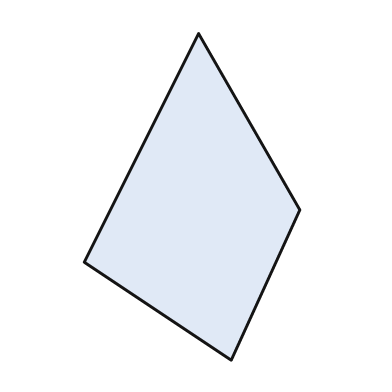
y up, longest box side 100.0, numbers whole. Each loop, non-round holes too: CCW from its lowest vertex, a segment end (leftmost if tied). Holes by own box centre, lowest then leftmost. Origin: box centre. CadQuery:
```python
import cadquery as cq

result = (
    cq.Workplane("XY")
    .moveTo(12.0, -50.0)
    .lineTo(33.0, -4.0)
    .lineTo(2.0, 50.0)
    .lineTo(-33.0, -20.0)
    .close()
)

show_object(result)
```